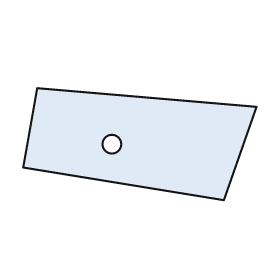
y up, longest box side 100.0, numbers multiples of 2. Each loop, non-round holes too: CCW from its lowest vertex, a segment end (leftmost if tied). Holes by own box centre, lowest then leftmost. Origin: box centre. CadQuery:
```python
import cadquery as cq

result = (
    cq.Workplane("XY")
    .moveTo(36.0, -24.0)
    .lineTo(50.0, 16.0)
    .lineTo(-44.0, 24.0)
    .lineTo(-50.0, -10.0)
    .close()
    .moveTo(-12.0, 0.0)
    .circle(4.0)
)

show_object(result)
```